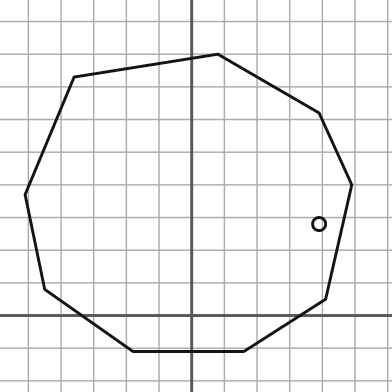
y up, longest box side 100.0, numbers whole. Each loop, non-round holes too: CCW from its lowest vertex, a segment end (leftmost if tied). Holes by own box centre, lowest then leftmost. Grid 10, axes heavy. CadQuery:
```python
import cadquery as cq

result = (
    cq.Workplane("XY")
    .moveTo(-18.0, -11.0)
    .lineTo(16.0, -11.0)
    .lineTo(41.0, 5.0)
    .lineTo(49.0, 40.0)
    .lineTo(39.0, 62.0)
    .lineTo(8.0, 80.0)
    .lineTo(-36.0, 73.0)
    .lineTo(-51.0, 37.0)
    .lineTo(-45.0, 8.0)
    .close()
    .moveTo(39.0, 28.0)
    .circle(2.0)
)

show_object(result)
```